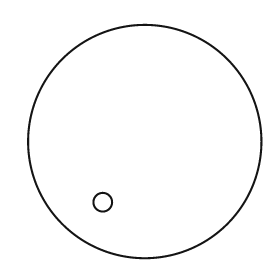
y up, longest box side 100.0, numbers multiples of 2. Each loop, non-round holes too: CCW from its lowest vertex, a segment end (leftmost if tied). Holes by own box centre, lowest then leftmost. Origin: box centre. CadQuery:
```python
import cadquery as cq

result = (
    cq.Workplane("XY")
    .moveTo(0.0, 0.0)
    .circle(50.0)
    .moveTo(-18.0, -26.0)
    .circle(4.0)
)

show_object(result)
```